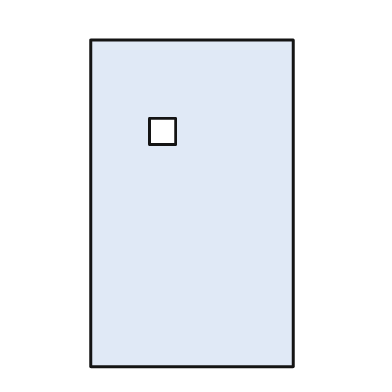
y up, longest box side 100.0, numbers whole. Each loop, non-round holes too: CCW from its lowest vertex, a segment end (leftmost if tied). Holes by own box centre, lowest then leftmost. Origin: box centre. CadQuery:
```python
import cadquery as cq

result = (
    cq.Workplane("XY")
    .moveTo(-31.0, -50.0)
    .lineTo(31.0, -50.0)
    .lineTo(31.0, 50.0)
    .lineTo(-31.0, 50.0)
    .close()
    .moveTo(-13.0, 18.0)
    .lineTo(-5.0, 18.0)
    .lineTo(-5.0, 26.0)
    .lineTo(-13.0, 26.0)
    .close()
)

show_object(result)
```